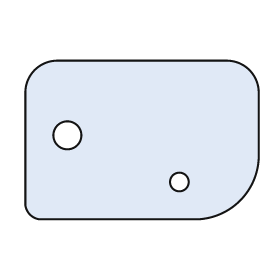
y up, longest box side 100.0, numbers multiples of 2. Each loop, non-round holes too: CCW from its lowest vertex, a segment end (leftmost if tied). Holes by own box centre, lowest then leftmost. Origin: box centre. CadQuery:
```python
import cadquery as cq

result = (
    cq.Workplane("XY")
    .moveTo(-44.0, -34.0)
    .lineTo(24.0, -34.0)
    .threePointArc((42.0, -26.0), (50.0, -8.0))
    .lineTo(50.0, 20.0)
    .threePointArc((46.0, 30.0), (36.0, 34.0))
    .lineTo(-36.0, 34.0)
    .threePointArc((-46.0, 30.0), (-50.0, 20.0))
    .lineTo(-50.0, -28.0)
    .threePointArc((-48.0, -32.0), (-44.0, -34.0))
    .close()
    .moveTo(16.0, -18.0)
    .circle(4.0)
    .moveTo(-32.0, 2.0)
    .circle(6.0)
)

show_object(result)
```